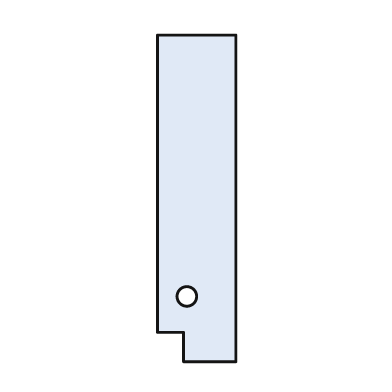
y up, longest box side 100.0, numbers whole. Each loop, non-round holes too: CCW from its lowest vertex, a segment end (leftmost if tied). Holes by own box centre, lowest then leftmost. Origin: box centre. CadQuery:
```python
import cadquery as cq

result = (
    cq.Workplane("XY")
    .moveTo(-4.0, -50.0)
    .lineTo(12.0, -50.0)
    .lineTo(12.0, 50.0)
    .lineTo(-12.0, 50.0)
    .lineTo(-12.0, -41.0)
    .lineTo(-4.0, -41.0)
    .close()
    .moveTo(-3.0, -30.0)
    .circle(3.0)
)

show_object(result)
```